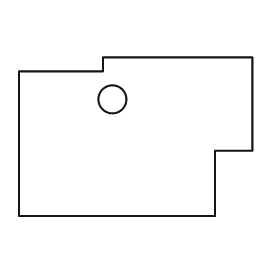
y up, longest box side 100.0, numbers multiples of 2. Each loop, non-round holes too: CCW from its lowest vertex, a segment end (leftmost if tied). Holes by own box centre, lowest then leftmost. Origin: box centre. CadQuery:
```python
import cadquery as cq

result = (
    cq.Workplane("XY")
    .moveTo(-50.0, -34.0)
    .lineTo(34.0, -34.0)
    .lineTo(34.0, -6.0)
    .lineTo(50.0, -6.0)
    .lineTo(50.0, 34.0)
    .lineTo(-14.0, 34.0)
    .lineTo(-14.0, 28.0)
    .lineTo(-50.0, 28.0)
    .close()
    .moveTo(-10.0, 16.0)
    .circle(6.0)
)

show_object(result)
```